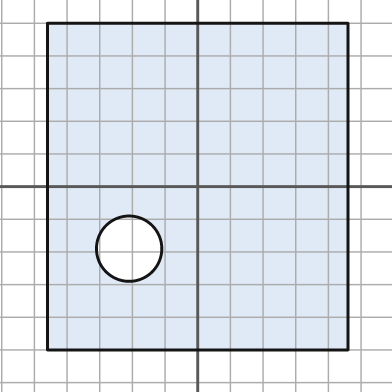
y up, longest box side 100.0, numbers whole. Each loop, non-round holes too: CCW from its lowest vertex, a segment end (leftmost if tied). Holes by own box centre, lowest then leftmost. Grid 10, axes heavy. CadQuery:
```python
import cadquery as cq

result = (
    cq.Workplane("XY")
    .moveTo(-46.0, -50.0)
    .lineTo(46.0, -50.0)
    .lineTo(46.0, 50.0)
    .lineTo(-46.0, 50.0)
    .close()
    .moveTo(-21.0, -19.0)
    .circle(10.0)
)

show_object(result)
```